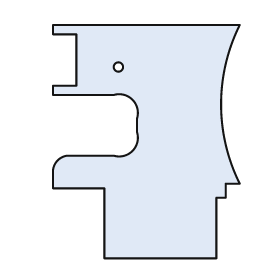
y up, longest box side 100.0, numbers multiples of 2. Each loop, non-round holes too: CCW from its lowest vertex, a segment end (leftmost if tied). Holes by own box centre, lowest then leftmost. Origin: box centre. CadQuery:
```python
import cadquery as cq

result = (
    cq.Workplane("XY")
    .moveTo(-18.0, -50.0)
    .lineTo(30.0, -50.0)
    .lineTo(30.0, -24.0)
    .lineTo(34.0, -24.0)
    .lineTo(34.0, -18.0)
    .lineTo(40.0, -18.0)
    .threePointArc((32.0, 16.0), (40.0, 50.0))
    .lineTo(-40.0, 50.0)
    .lineTo(-40.0, 46.0)
    .lineTo(-30.0, 46.0)
    .lineTo(-30.0, 24.0)
    .lineTo(-40.0, 24.0)
    .lineTo(-40.0, 20.0)
    .lineTo(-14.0, 20.0)
    .threePointArc((-6.0, 18.0), (-4.0, 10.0))
    .lineTo(-4.0, 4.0)
    .threePointArc((-6.0, -4.0), (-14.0, -6.0))
    .lineTo(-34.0, -6.0)
    .threePointArc((-38.0, -8.0), (-40.0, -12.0))
    .lineTo(-40.0, -20.0)
    .lineTo(-18.0, -20.0)
    .close()
    .moveTo(-12.0, 32.0)
    .circle(2.0)
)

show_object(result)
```